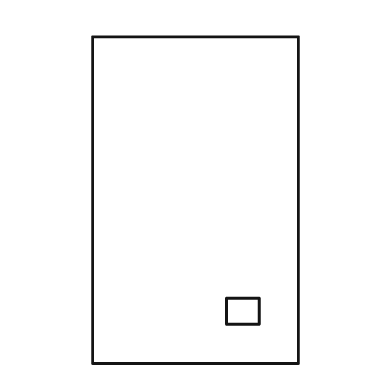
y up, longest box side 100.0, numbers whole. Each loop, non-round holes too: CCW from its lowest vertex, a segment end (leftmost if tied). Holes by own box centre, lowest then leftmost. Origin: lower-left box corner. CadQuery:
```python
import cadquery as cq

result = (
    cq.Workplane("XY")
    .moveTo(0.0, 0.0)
    .lineTo(63.0, 0.0)
    .lineTo(63.0, 100.0)
    .lineTo(0.0, 100.0)
    .close()
    .moveTo(41.0, 12.0)
    .lineTo(51.0, 12.0)
    .lineTo(51.0, 20.0)
    .lineTo(41.0, 20.0)
    .close()
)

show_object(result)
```